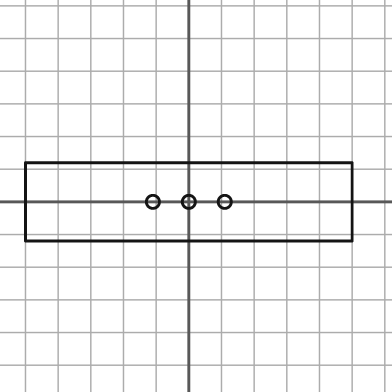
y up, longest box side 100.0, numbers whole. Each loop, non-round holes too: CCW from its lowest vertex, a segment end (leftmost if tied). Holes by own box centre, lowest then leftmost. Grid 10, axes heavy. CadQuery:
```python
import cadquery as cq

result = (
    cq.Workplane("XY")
    .moveTo(-50.0, -12.0)
    .lineTo(50.0, -12.0)
    .lineTo(50.0, 12.0)
    .lineTo(-50.0, 12.0)
    .close()
    .moveTo(-11.0, 0.0)
    .circle(2.0)
    .moveTo(0.0, 0.0)
    .circle(2.0)
    .moveTo(11.0, 0.0)
    .circle(2.0)
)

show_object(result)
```